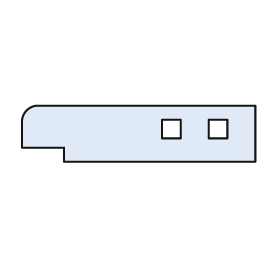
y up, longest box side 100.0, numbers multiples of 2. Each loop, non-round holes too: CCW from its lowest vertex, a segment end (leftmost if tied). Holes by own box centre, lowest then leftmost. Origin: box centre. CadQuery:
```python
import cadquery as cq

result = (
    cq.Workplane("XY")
    .moveTo(-32.0, -12.0)
    .lineTo(50.0, -12.0)
    .lineTo(50.0, 12.0)
    .lineTo(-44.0, 12.0)
    .threePointArc((-48.0, 10.0), (-50.0, 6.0))
    .lineTo(-50.0, -6.0)
    .lineTo(-32.0, -6.0)
    .close()
    .moveTo(10.0, -2.0)
    .lineTo(18.0, -2.0)
    .lineTo(18.0, 6.0)
    .lineTo(10.0, 6.0)
    .close()
    .moveTo(30.0, -2.0)
    .lineTo(38.0, -2.0)
    .lineTo(38.0, 6.0)
    .lineTo(30.0, 6.0)
    .close()
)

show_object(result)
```